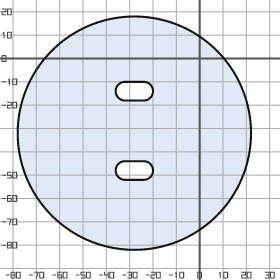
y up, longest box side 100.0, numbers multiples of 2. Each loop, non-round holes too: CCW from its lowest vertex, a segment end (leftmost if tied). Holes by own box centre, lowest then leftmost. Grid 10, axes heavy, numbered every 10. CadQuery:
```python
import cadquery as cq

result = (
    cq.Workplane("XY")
    .moveTo(-28.0, -32.0)
    .circle(50.0)
    .moveTo(-32.0, -52.0)
    .lineTo(-24.0, -52.0)
    .threePointArc((-20.0, -48.0), (-24.0, -44.0))
    .lineTo(-32.0, -44.0)
    .threePointArc((-36.0, -48.0), (-32.0, -52.0))
    .close()
    .moveTo(-32.0, -18.0)
    .lineTo(-24.0, -18.0)
    .threePointArc((-20.0, -14.0), (-24.0, -10.0))
    .lineTo(-32.0, -10.0)
    .threePointArc((-36.0, -14.0), (-32.0, -18.0))
    .close()
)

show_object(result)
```